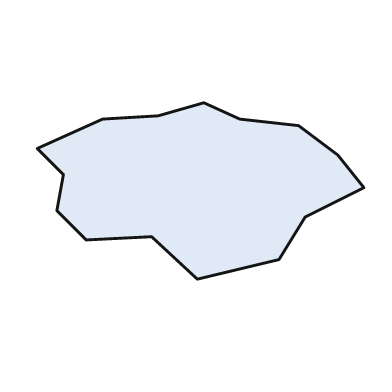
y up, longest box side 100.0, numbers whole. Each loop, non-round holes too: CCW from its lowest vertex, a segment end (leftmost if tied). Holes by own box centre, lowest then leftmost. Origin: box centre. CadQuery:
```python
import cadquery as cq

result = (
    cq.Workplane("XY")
    .moveTo(-1.0, -27.0)
    .lineTo(24.0, -21.0)
    .lineTo(32.0, -8.0)
    .lineTo(50.0, 1.0)
    .lineTo(42.0, 11.0)
    .lineTo(30.0, 20.0)
    .lineTo(12.0, 22.0)
    .lineTo(1.0, 27.0)
    .lineTo(-13.0, 23.0)
    .lineTo(-30.0, 22.0)
    .lineTo(-50.0, 13.0)
    .lineTo(-42.0, 5.0)
    .lineTo(-44.0, -6.0)
    .lineTo(-35.0, -15.0)
    .lineTo(-15.0, -14.0)
    .close()
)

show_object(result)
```